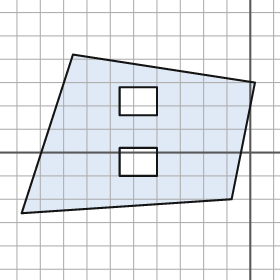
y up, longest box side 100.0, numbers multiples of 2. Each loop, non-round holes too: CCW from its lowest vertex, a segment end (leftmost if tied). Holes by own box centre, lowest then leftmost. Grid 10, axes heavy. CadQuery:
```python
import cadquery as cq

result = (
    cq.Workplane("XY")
    .moveTo(-98.0, -26.0)
    .lineTo(-8.0, -20.0)
    .lineTo(2.0, 30.0)
    .lineTo(-76.0, 42.0)
    .close()
    .moveTo(-56.0, -10.0)
    .lineTo(-40.0, -10.0)
    .lineTo(-40.0, 2.0)
    .lineTo(-56.0, 2.0)
    .close()
    .moveTo(-56.0, 16.0)
    .lineTo(-40.0, 16.0)
    .lineTo(-40.0, 28.0)
    .lineTo(-56.0, 28.0)
    .close()
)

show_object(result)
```